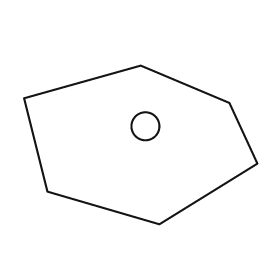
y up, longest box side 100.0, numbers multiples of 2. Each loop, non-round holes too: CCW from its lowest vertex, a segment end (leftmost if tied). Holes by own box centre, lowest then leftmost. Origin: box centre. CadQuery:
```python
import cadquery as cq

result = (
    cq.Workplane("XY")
    .moveTo(8.0, -34.0)
    .lineTo(50.0, -8.0)
    .lineTo(38.0, 18.0)
    .lineTo(0.0, 34.0)
    .lineTo(-50.0, 20.0)
    .lineTo(-40.0, -20.0)
    .close()
    .moveTo(2.0, 8.0)
    .circle(6.0)
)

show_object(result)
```